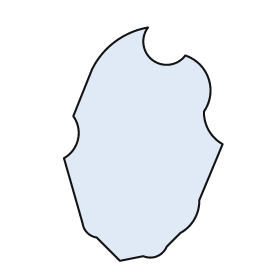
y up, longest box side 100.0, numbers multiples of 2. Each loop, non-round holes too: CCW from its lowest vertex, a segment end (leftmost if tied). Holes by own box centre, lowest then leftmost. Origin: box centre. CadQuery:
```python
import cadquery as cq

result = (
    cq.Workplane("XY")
    .moveTo(-10.0, -50.0)
    .lineTo(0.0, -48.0)
    .threePointArc((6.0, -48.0), (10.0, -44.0))
    .lineTo(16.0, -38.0)
    .threePointArc((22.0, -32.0), (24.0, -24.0))
    .lineTo(34.0, 0.0)
    .threePointArc((28.0, 6.0), (26.0, 14.0))
    .threePointArc((28.0, 28.0), (18.0, 38.0))
    .threePointArc((4.0, 36.0), (2.0, 50.0))
    .threePointArc((-12.0, 44.0), (-22.0, 32.0))
    .lineTo(-30.0, 12.0)
    .threePointArc((-28.0, 2.0), (-34.0, -6.0))
    .lineTo(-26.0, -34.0)
    .threePointArc((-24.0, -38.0), (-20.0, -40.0))
    .close()
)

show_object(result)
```